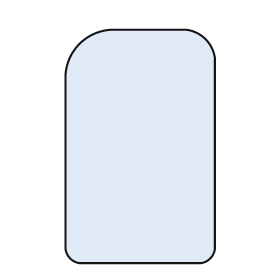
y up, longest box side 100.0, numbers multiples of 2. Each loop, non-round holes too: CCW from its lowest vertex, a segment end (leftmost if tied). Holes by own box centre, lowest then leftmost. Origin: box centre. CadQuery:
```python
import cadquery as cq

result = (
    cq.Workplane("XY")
    .moveTo(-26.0, -50.0)
    .lineTo(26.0, -50.0)
    .threePointArc((30.0, -48.0), (32.0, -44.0))
    .lineTo(32.0, 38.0)
    .threePointArc((28.0, 46.0), (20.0, 50.0))
    .lineTo(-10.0, 50.0)
    .threePointArc((-26.0, 44.0), (-32.0, 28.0))
    .lineTo(-32.0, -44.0)
    .threePointArc((-30.0, -48.0), (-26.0, -50.0))
    .close()
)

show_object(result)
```